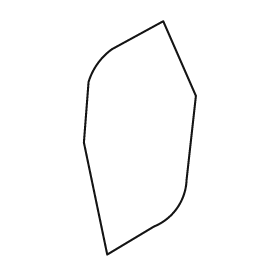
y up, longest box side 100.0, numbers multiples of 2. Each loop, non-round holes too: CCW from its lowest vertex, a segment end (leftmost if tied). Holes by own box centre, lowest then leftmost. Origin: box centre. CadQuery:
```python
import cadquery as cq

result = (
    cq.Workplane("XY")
    .moveTo(-14.0, -50.0)
    .lineTo(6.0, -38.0)
    .threePointArc((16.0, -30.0), (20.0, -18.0))
    .lineTo(24.0, 18.0)
    .lineTo(10.0, 50.0)
    .lineTo(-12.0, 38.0)
    .threePointArc((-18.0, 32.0), (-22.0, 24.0))
    .lineTo(-24.0, -2.0)
    .close()
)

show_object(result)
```